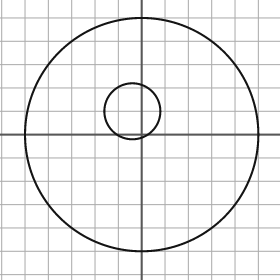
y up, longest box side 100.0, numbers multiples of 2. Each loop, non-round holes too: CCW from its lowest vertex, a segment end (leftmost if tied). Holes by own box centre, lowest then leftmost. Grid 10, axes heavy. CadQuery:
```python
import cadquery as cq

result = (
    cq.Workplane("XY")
    .moveTo(0.0, 0.0)
    .circle(50.0)
    .moveTo(-4.0, 10.0)
    .circle(12.0)
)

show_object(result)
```